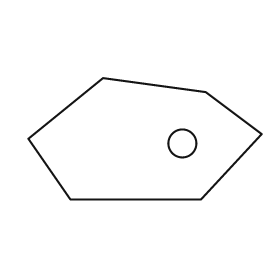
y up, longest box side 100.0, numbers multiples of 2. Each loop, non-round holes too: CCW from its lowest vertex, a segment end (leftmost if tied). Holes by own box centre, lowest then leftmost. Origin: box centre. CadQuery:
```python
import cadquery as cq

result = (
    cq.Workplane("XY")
    .moveTo(-32.0, -26.0)
    .lineTo(24.0, -26.0)
    .lineTo(50.0, 2.0)
    .lineTo(26.0, 20.0)
    .lineTo(-18.0, 26.0)
    .lineTo(-50.0, 0.0)
    .close()
    .moveTo(16.0, -2.0)
    .circle(6.0)
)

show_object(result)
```